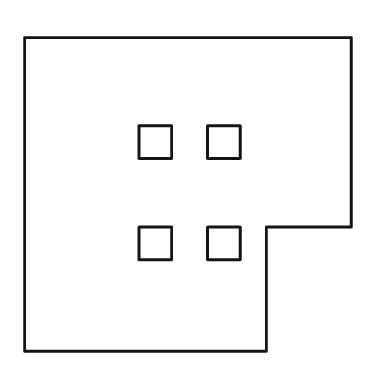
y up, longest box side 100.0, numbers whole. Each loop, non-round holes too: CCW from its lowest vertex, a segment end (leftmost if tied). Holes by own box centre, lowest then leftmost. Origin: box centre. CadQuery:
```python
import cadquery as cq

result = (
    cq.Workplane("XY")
    .moveTo(-50.0, -48.0)
    .lineTo(24.0, -48.0)
    .lineTo(24.0, -10.0)
    .lineTo(50.0, -10.0)
    .lineTo(50.0, 48.0)
    .lineTo(-50.0, 48.0)
    .close()
    .moveTo(-15.0, -20.0)
    .lineTo(-5.0, -20.0)
    .lineTo(-5.0, -10.0)
    .lineTo(-15.0, -10.0)
    .close()
    .moveTo(6.0, -20.0)
    .lineTo(16.0, -20.0)
    .lineTo(16.0, -10.0)
    .lineTo(6.0, -10.0)
    .close()
    .moveTo(-15.0, 11.0)
    .lineTo(-5.0, 11.0)
    .lineTo(-5.0, 21.0)
    .lineTo(-15.0, 21.0)
    .close()
    .moveTo(6.0, 11.0)
    .lineTo(16.0, 11.0)
    .lineTo(16.0, 21.0)
    .lineTo(6.0, 21.0)
    .close()
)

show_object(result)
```